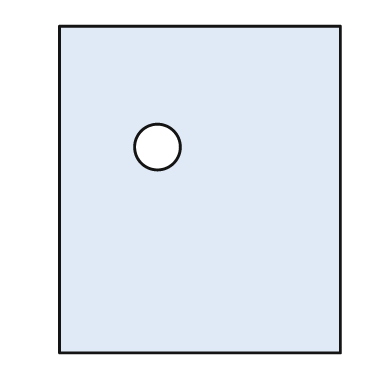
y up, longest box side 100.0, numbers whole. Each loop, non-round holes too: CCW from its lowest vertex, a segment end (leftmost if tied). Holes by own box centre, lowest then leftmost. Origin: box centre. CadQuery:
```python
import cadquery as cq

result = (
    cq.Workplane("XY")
    .moveTo(-43.0, -50.0)
    .lineTo(43.0, -50.0)
    .lineTo(43.0, 50.0)
    .lineTo(-43.0, 50.0)
    .close()
    .moveTo(-13.0, 13.0)
    .circle(7.0)
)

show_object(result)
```